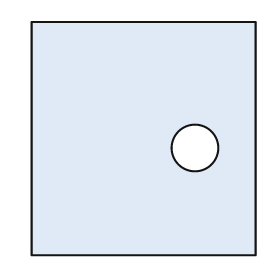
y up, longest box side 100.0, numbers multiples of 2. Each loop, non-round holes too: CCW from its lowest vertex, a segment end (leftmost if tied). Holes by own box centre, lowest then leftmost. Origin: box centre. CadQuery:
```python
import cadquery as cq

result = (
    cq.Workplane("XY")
    .moveTo(-48.0, -50.0)
    .lineTo(48.0, -50.0)
    .lineTo(48.0, 50.0)
    .lineTo(-48.0, 50.0)
    .close()
    .moveTo(22.0, -4.0)
    .circle(10.0)
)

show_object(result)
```